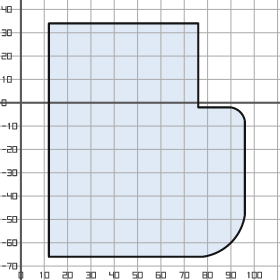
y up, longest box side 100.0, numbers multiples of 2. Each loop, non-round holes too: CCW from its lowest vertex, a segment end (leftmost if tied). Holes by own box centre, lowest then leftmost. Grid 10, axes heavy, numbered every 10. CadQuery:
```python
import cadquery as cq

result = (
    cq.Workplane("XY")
    .moveTo(12.0, -66.0)
    .lineTo(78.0, -66.0)
    .threePointArc((90.0, -60.0), (96.0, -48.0))
    .lineTo(96.0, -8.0)
    .threePointArc((94.0, -4.0), (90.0, -2.0))
    .lineTo(76.0, -2.0)
    .lineTo(76.0, 34.0)
    .lineTo(12.0, 34.0)
    .close()
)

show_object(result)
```